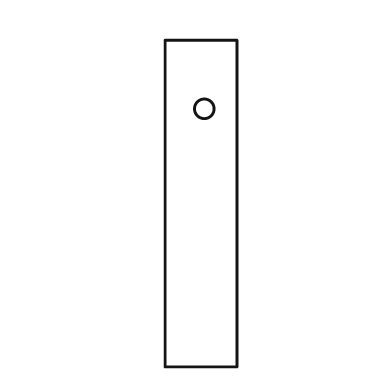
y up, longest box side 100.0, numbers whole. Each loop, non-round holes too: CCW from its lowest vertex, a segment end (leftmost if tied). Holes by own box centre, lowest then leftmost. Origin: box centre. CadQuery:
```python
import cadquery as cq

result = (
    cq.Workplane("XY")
    .moveTo(-11.0, -50.0)
    .lineTo(11.0, -50.0)
    .lineTo(11.0, 50.0)
    .lineTo(-11.0, 50.0)
    .close()
    .moveTo(1.0, 29.0)
    .circle(3.0)
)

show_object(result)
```